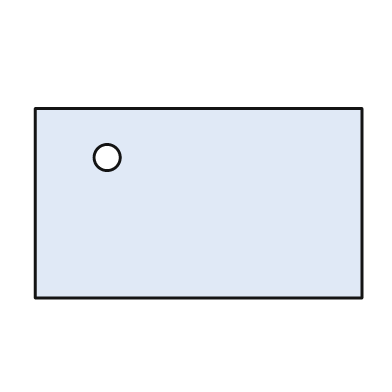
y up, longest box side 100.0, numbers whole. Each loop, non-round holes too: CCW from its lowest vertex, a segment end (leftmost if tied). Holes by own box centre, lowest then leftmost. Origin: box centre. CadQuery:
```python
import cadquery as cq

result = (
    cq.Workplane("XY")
    .moveTo(-50.0, -29.0)
    .lineTo(50.0, -29.0)
    .lineTo(50.0, 29.0)
    .lineTo(-50.0, 29.0)
    .close()
    .moveTo(-28.0, 14.0)
    .circle(4.0)
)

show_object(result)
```